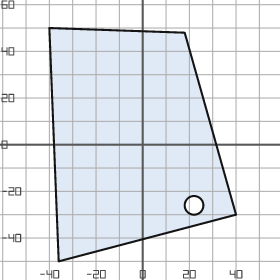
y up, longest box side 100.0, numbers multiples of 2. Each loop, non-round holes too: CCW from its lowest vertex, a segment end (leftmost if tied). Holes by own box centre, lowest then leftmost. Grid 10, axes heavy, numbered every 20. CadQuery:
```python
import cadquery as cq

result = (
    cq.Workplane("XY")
    .moveTo(-36.0, -50.0)
    .lineTo(40.0, -30.0)
    .lineTo(18.0, 48.0)
    .lineTo(-40.0, 50.0)
    .close()
    .moveTo(22.0, -26.0)
    .circle(4.0)
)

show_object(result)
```